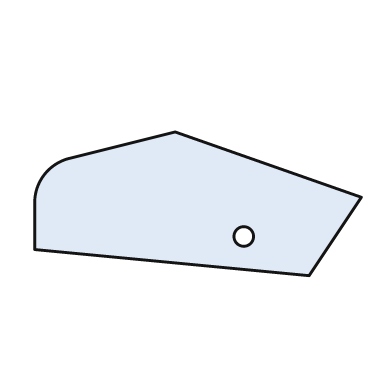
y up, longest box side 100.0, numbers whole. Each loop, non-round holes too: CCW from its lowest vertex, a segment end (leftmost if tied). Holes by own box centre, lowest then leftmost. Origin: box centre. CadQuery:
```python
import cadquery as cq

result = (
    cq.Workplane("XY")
    .moveTo(34.0, -22.0)
    .lineTo(50.0, 2.0)
    .lineTo(-7.0, 22.0)
    .lineTo(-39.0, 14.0)
    .threePointArc((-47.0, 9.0), (-50.0, 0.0))
    .lineTo(-50.0, -14.0)
    .close()
    .moveTo(14.0, -10.0)
    .circle(3.0)
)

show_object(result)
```